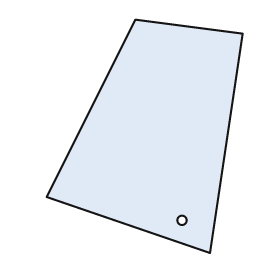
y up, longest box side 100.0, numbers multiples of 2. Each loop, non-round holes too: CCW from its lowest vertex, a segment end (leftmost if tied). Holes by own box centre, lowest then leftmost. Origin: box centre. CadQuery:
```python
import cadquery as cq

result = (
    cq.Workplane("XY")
    .moveTo(28.0, -50.0)
    .lineTo(42.0, 44.0)
    .lineTo(-4.0, 50.0)
    .lineTo(-42.0, -26.0)
    .close()
    .moveTo(16.0, -36.0)
    .circle(2.0)
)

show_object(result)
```